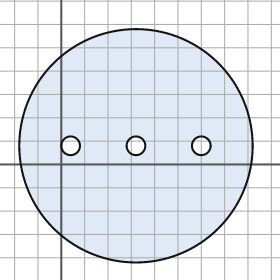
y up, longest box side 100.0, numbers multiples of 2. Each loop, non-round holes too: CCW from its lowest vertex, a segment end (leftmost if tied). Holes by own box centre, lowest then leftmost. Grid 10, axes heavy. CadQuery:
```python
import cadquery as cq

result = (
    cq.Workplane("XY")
    .moveTo(32.0, 8.0)
    .circle(50.0)
    .moveTo(4.0, 8.0)
    .circle(4.0)
    .moveTo(32.0, 8.0)
    .circle(4.0)
    .moveTo(60.0, 8.0)
    .circle(4.0)
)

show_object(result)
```